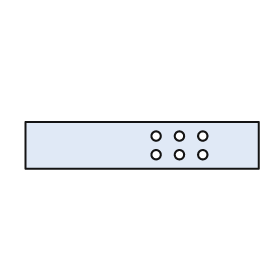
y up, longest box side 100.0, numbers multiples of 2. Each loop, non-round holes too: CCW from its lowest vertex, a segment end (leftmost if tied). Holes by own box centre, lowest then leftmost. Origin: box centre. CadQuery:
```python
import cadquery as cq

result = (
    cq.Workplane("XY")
    .moveTo(-50.0, -10.0)
    .lineTo(50.0, -10.0)
    .lineTo(50.0, 10.0)
    .lineTo(-50.0, 10.0)
    .close()
    .moveTo(6.0, -4.0)
    .circle(2.0)
    .moveTo(16.0, -4.0)
    .circle(2.0)
    .moveTo(26.0, -4.0)
    .circle(2.0)
    .moveTo(6.0, 4.0)
    .circle(2.0)
    .moveTo(16.0, 4.0)
    .circle(2.0)
    .moveTo(26.0, 4.0)
    .circle(2.0)
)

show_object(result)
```